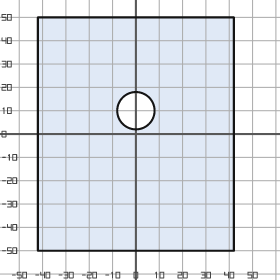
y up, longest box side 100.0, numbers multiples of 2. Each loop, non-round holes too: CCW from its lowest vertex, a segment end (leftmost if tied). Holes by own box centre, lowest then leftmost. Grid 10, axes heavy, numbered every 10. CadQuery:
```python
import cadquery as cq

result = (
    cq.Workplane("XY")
    .moveTo(-42.0, -50.0)
    .lineTo(42.0, -50.0)
    .lineTo(42.0, 50.0)
    .lineTo(-42.0, 50.0)
    .close()
    .moveTo(0.0, 10.0)
    .circle(8.0)
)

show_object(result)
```